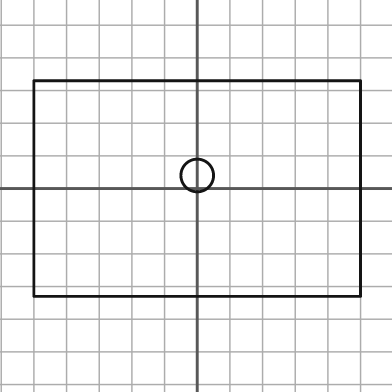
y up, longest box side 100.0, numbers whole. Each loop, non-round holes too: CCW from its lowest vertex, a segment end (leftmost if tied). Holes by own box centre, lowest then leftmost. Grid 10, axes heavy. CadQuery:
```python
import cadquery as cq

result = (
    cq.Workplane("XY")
    .moveTo(-50.0, -33.0)
    .lineTo(50.0, -33.0)
    .lineTo(50.0, 33.0)
    .lineTo(-50.0, 33.0)
    .close()
    .moveTo(0.0, 4.0)
    .circle(5.0)
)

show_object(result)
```